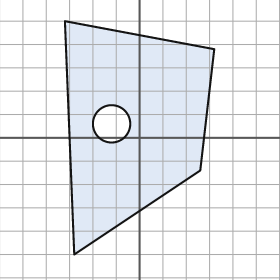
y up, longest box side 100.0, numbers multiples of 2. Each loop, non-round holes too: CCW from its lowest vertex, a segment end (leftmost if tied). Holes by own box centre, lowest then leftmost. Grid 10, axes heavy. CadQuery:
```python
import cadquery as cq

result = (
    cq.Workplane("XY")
    .moveTo(-28.0, -50.0)
    .lineTo(26.0, -14.0)
    .lineTo(32.0, 38.0)
    .lineTo(-32.0, 50.0)
    .close()
    .moveTo(-12.0, 6.0)
    .circle(8.0)
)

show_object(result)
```